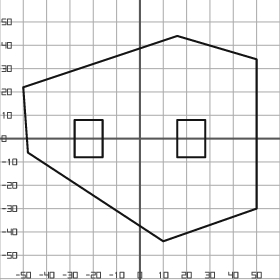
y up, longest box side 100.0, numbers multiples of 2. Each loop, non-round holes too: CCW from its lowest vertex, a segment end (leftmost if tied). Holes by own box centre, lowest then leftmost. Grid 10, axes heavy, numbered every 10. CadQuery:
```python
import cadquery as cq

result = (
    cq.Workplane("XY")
    .moveTo(10.0, -44.0)
    .lineTo(50.0, -30.0)
    .lineTo(50.0, 34.0)
    .lineTo(16.0, 44.0)
    .lineTo(-50.0, 22.0)
    .lineTo(-48.0, -6.0)
    .close()
    .moveTo(-28.0, -8.0)
    .lineTo(-16.0, -8.0)
    .lineTo(-16.0, 8.0)
    .lineTo(-28.0, 8.0)
    .close()
    .moveTo(16.0, -8.0)
    .lineTo(28.0, -8.0)
    .lineTo(28.0, 8.0)
    .lineTo(16.0, 8.0)
    .close()
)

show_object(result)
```